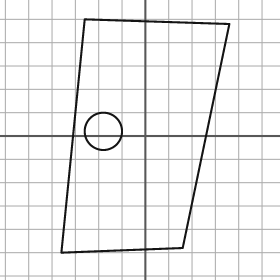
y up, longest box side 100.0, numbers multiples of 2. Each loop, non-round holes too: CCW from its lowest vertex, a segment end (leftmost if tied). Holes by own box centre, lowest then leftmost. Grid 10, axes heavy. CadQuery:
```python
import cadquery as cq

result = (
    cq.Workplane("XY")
    .moveTo(-36.0, -50.0)
    .lineTo(16.0, -48.0)
    .lineTo(36.0, 48.0)
    .lineTo(-26.0, 50.0)
    .close()
    .moveTo(-18.0, 2.0)
    .circle(8.0)
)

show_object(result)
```